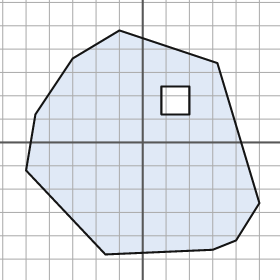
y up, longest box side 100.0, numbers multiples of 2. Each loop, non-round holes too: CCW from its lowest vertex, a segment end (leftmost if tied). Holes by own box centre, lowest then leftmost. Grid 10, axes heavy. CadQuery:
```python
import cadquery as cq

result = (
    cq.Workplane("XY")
    .moveTo(-16.0, -48.0)
    .lineTo(30.0, -46.0)
    .lineTo(40.0, -42.0)
    .lineTo(50.0, -26.0)
    .lineTo(32.0, 34.0)
    .lineTo(-10.0, 48.0)
    .lineTo(-30.0, 36.0)
    .lineTo(-46.0, 12.0)
    .lineTo(-50.0, -12.0)
    .close()
    .moveTo(8.0, 12.0)
    .lineTo(20.0, 12.0)
    .lineTo(20.0, 24.0)
    .lineTo(8.0, 24.0)
    .close()
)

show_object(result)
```